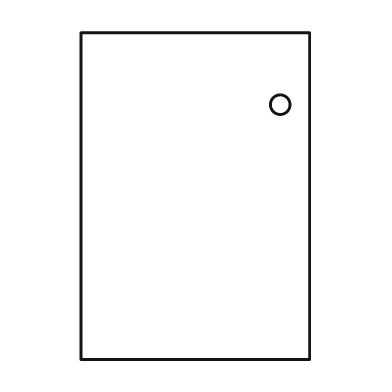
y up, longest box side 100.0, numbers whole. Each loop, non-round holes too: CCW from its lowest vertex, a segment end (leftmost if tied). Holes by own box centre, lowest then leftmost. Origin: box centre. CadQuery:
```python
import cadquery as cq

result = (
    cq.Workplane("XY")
    .moveTo(-35.0, -50.0)
    .lineTo(35.0, -50.0)
    .lineTo(35.0, 50.0)
    .lineTo(-35.0, 50.0)
    .close()
    .moveTo(26.0, 28.0)
    .circle(3.0)
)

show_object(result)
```